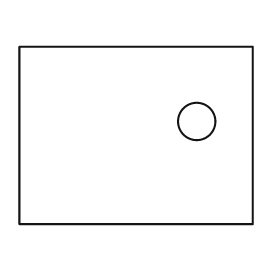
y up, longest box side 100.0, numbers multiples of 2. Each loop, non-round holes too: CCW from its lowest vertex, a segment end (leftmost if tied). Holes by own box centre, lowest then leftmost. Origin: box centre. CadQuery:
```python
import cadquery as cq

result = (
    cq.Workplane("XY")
    .moveTo(-50.0, -38.0)
    .lineTo(50.0, -38.0)
    .lineTo(50.0, 38.0)
    .lineTo(-50.0, 38.0)
    .close()
    .moveTo(26.0, 6.0)
    .circle(8.0)
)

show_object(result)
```